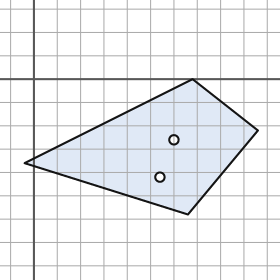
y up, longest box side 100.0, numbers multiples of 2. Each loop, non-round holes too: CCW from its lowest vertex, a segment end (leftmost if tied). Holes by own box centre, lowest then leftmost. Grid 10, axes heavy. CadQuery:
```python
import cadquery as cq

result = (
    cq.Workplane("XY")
    .moveTo(66.0, -58.0)
    .lineTo(96.0, -22.0)
    .lineTo(68.0, 0.0)
    .lineTo(-4.0, -36.0)
    .close()
    .moveTo(54.0, -42.0)
    .circle(2.0)
    .moveTo(60.0, -26.0)
    .circle(2.0)
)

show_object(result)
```